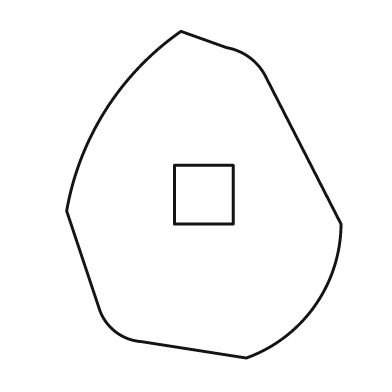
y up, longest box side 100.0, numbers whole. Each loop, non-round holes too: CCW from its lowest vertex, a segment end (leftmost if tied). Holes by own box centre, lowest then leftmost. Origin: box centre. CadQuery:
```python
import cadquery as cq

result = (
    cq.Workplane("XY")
    .moveTo(13.0, -50.0)
    .threePointArc((34.0, -34.0), (42.0, -9.0))
    .lineTo(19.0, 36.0)
    .threePointArc((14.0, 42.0), (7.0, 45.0))
    .lineTo(-7.0, 50.0)
    .threePointArc((-30.0, 26.0), (-42.0, -5.0))
    .lineTo(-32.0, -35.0)
    .threePointArc((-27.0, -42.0), (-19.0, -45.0))
    .close()
    .moveTo(-9.0, -9.0)
    .lineTo(9.0, -9.0)
    .lineTo(9.0, 9.0)
    .lineTo(-9.0, 9.0)
    .close()
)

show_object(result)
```